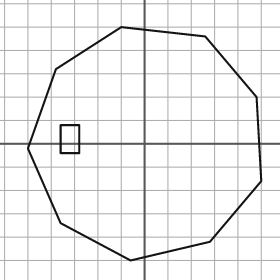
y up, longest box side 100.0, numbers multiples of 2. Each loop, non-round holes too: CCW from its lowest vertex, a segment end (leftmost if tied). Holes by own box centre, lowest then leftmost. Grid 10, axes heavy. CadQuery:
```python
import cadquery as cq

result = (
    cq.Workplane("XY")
    .moveTo(-6.0, -50.0)
    .lineTo(28.0, -42.0)
    .lineTo(50.0, -16.0)
    .lineTo(48.0, 20.0)
    .lineTo(26.0, 46.0)
    .lineTo(-10.0, 50.0)
    .lineTo(-38.0, 32.0)
    .lineTo(-50.0, -2.0)
    .lineTo(-36.0, -34.0)
    .close()
    .moveTo(-36.0, -4.0)
    .lineTo(-28.0, -4.0)
    .lineTo(-28.0, 8.0)
    .lineTo(-36.0, 8.0)
    .close()
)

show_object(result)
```